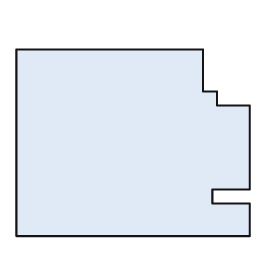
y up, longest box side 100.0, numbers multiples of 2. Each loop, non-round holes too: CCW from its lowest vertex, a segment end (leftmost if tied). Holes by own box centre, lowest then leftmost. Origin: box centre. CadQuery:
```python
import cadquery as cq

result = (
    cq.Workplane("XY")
    .moveTo(-50.0, -40.0)
    .lineTo(50.0, -40.0)
    .lineTo(50.0, -26.0)
    .lineTo(34.0, -26.0)
    .lineTo(34.0, -20.0)
    .lineTo(50.0, -20.0)
    .lineTo(50.0, 16.0)
    .lineTo(36.0, 16.0)
    .lineTo(36.0, 22.0)
    .lineTo(30.0, 22.0)
    .lineTo(30.0, 40.0)
    .lineTo(-50.0, 40.0)
    .close()
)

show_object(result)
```